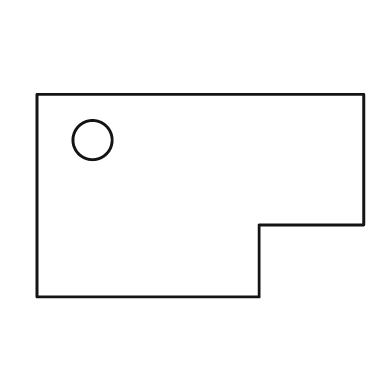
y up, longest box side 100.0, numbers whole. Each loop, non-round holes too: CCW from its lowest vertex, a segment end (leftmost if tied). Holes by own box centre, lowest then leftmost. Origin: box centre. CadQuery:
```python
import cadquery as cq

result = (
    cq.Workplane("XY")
    .moveTo(-50.0, -31.0)
    .lineTo(18.0, -31.0)
    .lineTo(18.0, -9.0)
    .lineTo(50.0, -9.0)
    .lineTo(50.0, 31.0)
    .lineTo(-50.0, 31.0)
    .close()
    .moveTo(-33.0, 17.0)
    .circle(6.0)
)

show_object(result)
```